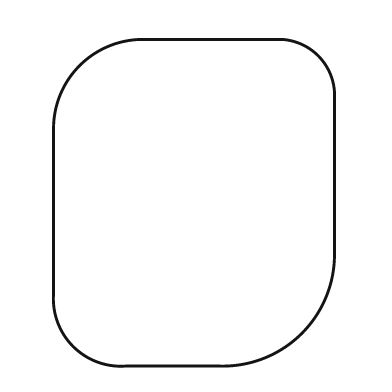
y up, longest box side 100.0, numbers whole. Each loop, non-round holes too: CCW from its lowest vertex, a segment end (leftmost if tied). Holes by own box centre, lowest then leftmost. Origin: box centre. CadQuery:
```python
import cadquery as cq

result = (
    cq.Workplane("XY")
    .moveTo(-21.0, -50.0)
    .lineTo(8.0, -50.0)
    .threePointArc((33.0, -40.0), (43.0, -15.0))
    .lineTo(43.0, 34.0)
    .threePointArc((38.0, 45.0), (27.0, 50.0))
    .lineTo(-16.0, 50.0)
    .threePointArc((-35.0, 42.0), (-43.0, 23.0))
    .lineTo(-43.0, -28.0)
    .threePointArc((-37.0, -44.0), (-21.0, -50.0))
    .close()
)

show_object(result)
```